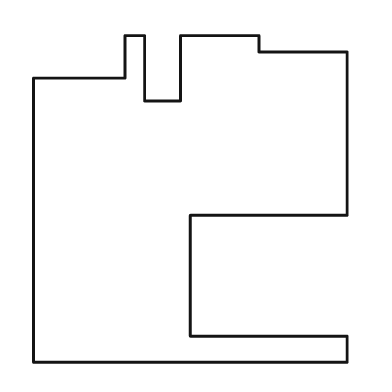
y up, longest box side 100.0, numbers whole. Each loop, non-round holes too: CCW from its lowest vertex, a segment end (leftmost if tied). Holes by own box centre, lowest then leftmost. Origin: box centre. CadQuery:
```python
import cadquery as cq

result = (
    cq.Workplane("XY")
    .moveTo(-48.0, -50.0)
    .lineTo(48.0, -50.0)
    .lineTo(48.0, -42.0)
    .lineTo(0.0, -42.0)
    .lineTo(0.0, -5.0)
    .lineTo(48.0, -5.0)
    .lineTo(48.0, 45.0)
    .lineTo(21.0, 45.0)
    .lineTo(21.0, 50.0)
    .lineTo(-3.0, 50.0)
    .lineTo(-3.0, 30.0)
    .lineTo(-14.0, 30.0)
    .lineTo(-14.0, 50.0)
    .lineTo(-20.0, 50.0)
    .lineTo(-20.0, 37.0)
    .lineTo(-48.0, 37.0)
    .close()
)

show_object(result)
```